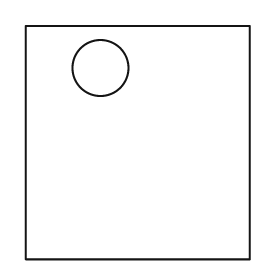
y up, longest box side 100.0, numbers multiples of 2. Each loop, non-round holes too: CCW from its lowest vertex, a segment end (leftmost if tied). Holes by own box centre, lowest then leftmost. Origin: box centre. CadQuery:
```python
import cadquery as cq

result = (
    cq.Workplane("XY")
    .moveTo(-48.0, -50.0)
    .lineTo(48.0, -50.0)
    .lineTo(48.0, 50.0)
    .lineTo(-48.0, 50.0)
    .close()
    .moveTo(-16.0, 32.0)
    .circle(12.0)
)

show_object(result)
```